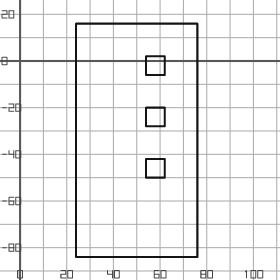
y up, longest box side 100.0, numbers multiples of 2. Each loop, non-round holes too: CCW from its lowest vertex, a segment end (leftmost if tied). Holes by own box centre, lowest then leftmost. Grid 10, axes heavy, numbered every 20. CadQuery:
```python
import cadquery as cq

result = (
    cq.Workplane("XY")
    .moveTo(24.0, -84.0)
    .lineTo(76.0, -84.0)
    .lineTo(76.0, 16.0)
    .lineTo(24.0, 16.0)
    .close()
    .moveTo(54.0, -50.0)
    .lineTo(62.0, -50.0)
    .lineTo(62.0, -42.0)
    .lineTo(54.0, -42.0)
    .close()
    .moveTo(54.0, -28.0)
    .lineTo(62.0, -28.0)
    .lineTo(62.0, -20.0)
    .lineTo(54.0, -20.0)
    .close()
    .moveTo(54.0, -6.0)
    .lineTo(62.0, -6.0)
    .lineTo(62.0, 2.0)
    .lineTo(54.0, 2.0)
    .close()
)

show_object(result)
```